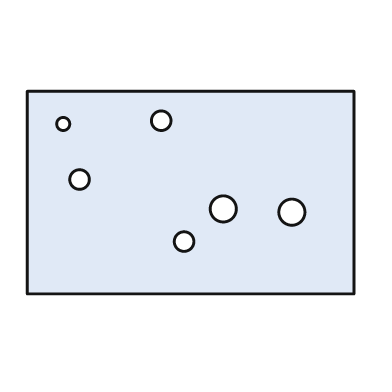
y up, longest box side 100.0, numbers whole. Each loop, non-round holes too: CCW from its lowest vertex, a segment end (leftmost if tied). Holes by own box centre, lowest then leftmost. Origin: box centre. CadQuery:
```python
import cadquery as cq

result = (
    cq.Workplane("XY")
    .moveTo(-50.0, -31.0)
    .lineTo(50.0, -31.0)
    .lineTo(50.0, 31.0)
    .lineTo(-50.0, 31.0)
    .close()
    .moveTo(-2.0, -15.0)
    .circle(3.0)
    .moveTo(31.0, -6.0)
    .circle(4.0)
    .moveTo(10.0, -5.0)
    .circle(4.0)
    .moveTo(-34.0, 4.0)
    .circle(3.0)
    .moveTo(-39.0, 21.0)
    .circle(2.0)
    .moveTo(-9.0, 22.0)
    .circle(3.0)
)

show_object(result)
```